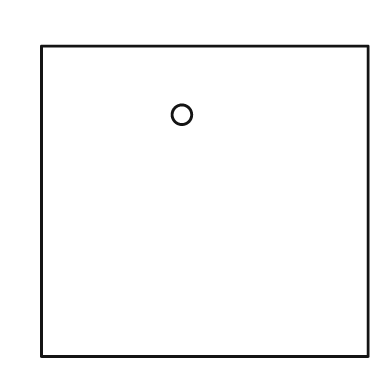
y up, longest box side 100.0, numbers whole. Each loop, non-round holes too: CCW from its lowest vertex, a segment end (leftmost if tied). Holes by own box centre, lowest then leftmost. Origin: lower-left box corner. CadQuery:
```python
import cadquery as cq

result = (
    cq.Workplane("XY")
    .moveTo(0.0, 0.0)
    .lineTo(100.0, 0.0)
    .lineTo(100.0, 95.0)
    .lineTo(0.0, 95.0)
    .close()
    .moveTo(43.0, 74.0)
    .circle(3.0)
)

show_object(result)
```